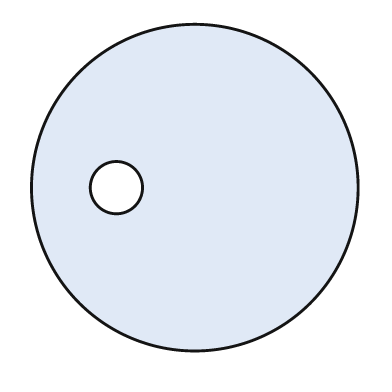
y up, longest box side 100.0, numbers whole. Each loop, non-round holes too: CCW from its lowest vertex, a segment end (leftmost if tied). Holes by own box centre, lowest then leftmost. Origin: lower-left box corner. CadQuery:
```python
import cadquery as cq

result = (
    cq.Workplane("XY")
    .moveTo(50.0, 50.0)
    .circle(50.0)
    .moveTo(26.0, 50.0)
    .circle(8.0)
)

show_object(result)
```